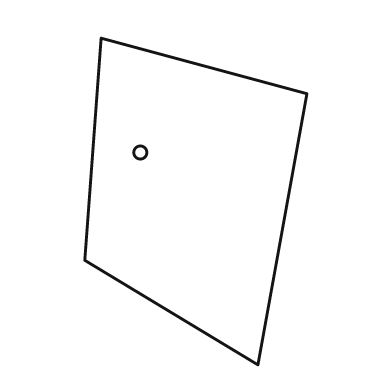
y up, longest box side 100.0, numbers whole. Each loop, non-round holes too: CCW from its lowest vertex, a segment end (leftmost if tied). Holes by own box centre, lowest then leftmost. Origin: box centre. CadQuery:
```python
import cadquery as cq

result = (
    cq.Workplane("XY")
    .moveTo(19.0, -50.0)
    .lineTo(34.0, 33.0)
    .lineTo(-29.0, 50.0)
    .lineTo(-34.0, -18.0)
    .close()
    .moveTo(-17.0, 15.0)
    .circle(2.0)
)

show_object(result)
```